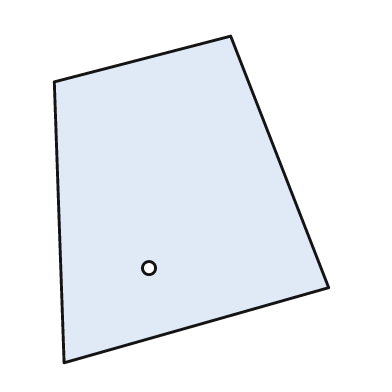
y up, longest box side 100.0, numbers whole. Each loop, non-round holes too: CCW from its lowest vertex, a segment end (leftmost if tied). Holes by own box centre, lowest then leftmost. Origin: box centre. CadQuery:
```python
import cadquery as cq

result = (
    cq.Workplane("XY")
    .moveTo(-39.0, -50.0)
    .lineTo(42.0, -27.0)
    .lineTo(12.0, 50.0)
    .lineTo(-42.0, 36.0)
    .close()
    .moveTo(-13.0, -21.0)
    .circle(2.0)
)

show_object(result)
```